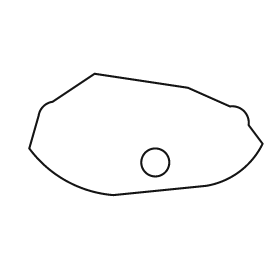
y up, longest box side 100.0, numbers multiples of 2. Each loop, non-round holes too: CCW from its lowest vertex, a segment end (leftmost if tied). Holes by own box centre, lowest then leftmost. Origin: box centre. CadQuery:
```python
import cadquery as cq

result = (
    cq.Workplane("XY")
    .moveTo(-14.0, -26.0)
    .lineTo(26.0, -22.0)
    .threePointArc((40.0, -16.0), (50.0, -4.0))
    .lineTo(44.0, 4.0)
    .threePointArc((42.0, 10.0), (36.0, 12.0))
    .lineTo(18.0, 20.0)
    .lineTo(-22.0, 26.0)
    .lineTo(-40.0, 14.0)
    .threePointArc((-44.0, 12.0), (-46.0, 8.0))
    .lineTo(-50.0, -6.0)
    .threePointArc((-34.0, -20.0), (-14.0, -26.0))
    .close()
    .moveTo(4.0, -12.0)
    .circle(6.0)
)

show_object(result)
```